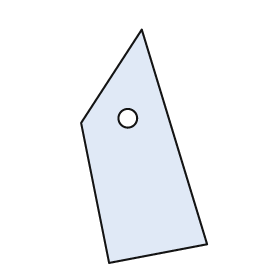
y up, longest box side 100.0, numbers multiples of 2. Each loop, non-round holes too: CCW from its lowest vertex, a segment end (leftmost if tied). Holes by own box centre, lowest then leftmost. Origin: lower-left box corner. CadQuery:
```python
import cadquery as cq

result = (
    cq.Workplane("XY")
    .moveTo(12.0, 0.0)
    .lineTo(54.0, 8.0)
    .lineTo(26.0, 100.0)
    .lineTo(0.0, 60.0)
    .close()
    .moveTo(20.0, 62.0)
    .circle(4.0)
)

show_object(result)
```